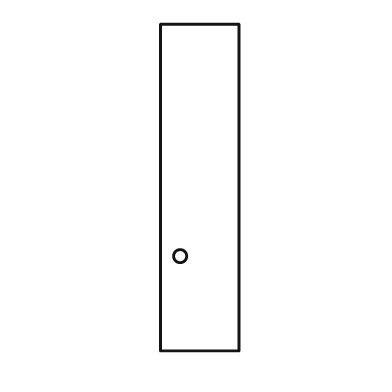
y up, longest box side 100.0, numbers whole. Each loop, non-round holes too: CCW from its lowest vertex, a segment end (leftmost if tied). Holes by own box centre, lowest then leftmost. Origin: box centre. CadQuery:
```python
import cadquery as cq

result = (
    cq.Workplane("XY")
    .moveTo(-12.0, -50.0)
    .lineTo(12.0, -50.0)
    .lineTo(12.0, 50.0)
    .lineTo(-12.0, 50.0)
    .close()
    .moveTo(-6.0, -21.0)
    .circle(2.0)
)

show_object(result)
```